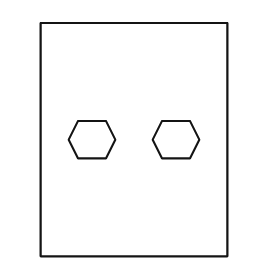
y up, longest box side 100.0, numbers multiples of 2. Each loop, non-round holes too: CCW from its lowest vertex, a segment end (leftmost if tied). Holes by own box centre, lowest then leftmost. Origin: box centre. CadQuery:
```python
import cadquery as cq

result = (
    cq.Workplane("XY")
    .moveTo(-40.0, -50.0)
    .lineTo(40.0, -50.0)
    .lineTo(40.0, 50.0)
    .lineTo(-40.0, 50.0)
    .close()
    .moveTo(-24.0, -8.0)
    .lineTo(-12.0, -8.0)
    .lineTo(-8.0, 0.0)
    .lineTo(-12.0, 8.0)
    .lineTo(-24.0, 8.0)
    .lineTo(-28.0, 0.0)
    .close()
    .moveTo(12.0, -8.0)
    .lineTo(24.0, -8.0)
    .lineTo(28.0, 0.0)
    .lineTo(24.0, 8.0)
    .lineTo(12.0, 8.0)
    .lineTo(8.0, 0.0)
    .close()
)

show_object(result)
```